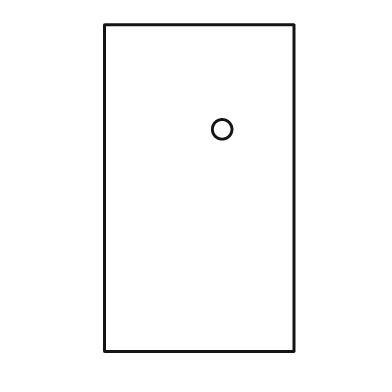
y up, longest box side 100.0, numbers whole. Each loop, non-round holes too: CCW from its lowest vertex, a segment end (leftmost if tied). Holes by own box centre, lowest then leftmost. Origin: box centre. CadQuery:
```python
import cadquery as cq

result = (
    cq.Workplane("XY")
    .moveTo(-29.0, -50.0)
    .lineTo(29.0, -50.0)
    .lineTo(29.0, 50.0)
    .lineTo(-29.0, 50.0)
    .close()
    .moveTo(7.0, 18.0)
    .circle(3.0)
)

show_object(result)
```